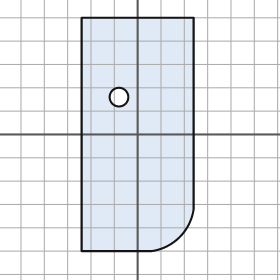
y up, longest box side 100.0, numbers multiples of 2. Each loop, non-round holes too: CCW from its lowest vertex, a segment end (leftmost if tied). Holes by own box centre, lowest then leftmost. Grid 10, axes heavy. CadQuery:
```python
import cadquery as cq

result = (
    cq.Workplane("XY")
    .moveTo(-24.0, -50.0)
    .lineTo(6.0, -50.0)
    .threePointArc((18.0, -44.0), (24.0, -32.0))
    .lineTo(24.0, 50.0)
    .lineTo(-24.0, 50.0)
    .close()
    .moveTo(-8.0, 16.0)
    .circle(4.0)
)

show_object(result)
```